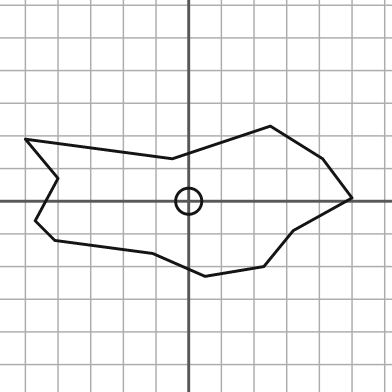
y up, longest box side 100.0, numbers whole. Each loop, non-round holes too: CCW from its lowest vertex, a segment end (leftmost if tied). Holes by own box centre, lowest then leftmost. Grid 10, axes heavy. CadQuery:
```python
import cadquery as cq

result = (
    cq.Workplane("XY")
    .moveTo(5.0, -23.0)
    .lineTo(23.0, -20.0)
    .lineTo(32.0, -9.0)
    .lineTo(50.0, 1.0)
    .lineTo(41.0, 13.0)
    .lineTo(25.0, 23.0)
    .lineTo(-5.0, 13.0)
    .lineTo(-50.0, 19.0)
    .lineTo(-40.0, 7.0)
    .lineTo(-47.0, -6.0)
    .lineTo(-41.0, -12.0)
    .lineTo(-11.0, -16.0)
    .close()
    .moveTo(0.0, 0.0)
    .circle(4.0)
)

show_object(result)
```